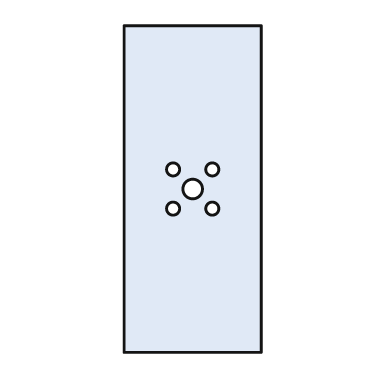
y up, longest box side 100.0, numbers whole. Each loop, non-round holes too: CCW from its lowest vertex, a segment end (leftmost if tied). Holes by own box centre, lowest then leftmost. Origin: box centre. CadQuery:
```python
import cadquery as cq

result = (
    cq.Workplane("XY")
    .moveTo(-21.0, -50.0)
    .lineTo(21.0, -50.0)
    .lineTo(21.0, 50.0)
    .lineTo(-21.0, 50.0)
    .close()
    .moveTo(-6.0, -6.0)
    .circle(2.0)
    .moveTo(6.0, -6.0)
    .circle(2.0)
    .moveTo(0.0, 0.0)
    .circle(3.0)
    .moveTo(-6.0, 6.0)
    .circle(2.0)
    .moveTo(6.0, 6.0)
    .circle(2.0)
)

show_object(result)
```